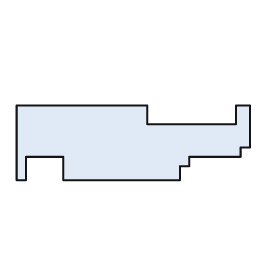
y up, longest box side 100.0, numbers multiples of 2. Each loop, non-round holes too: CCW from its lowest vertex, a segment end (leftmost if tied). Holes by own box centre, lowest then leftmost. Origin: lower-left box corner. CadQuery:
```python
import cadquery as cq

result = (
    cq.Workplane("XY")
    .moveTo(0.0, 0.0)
    .lineTo(4.0, 0.0)
    .lineTo(4.0, 10.0)
    .lineTo(20.0, 10.0)
    .lineTo(20.0, 0.0)
    .lineTo(70.0, 0.0)
    .lineTo(70.0, 6.0)
    .lineTo(74.0, 6.0)
    .lineTo(74.0, 10.0)
    .lineTo(96.0, 10.0)
    .lineTo(96.0, 14.0)
    .lineTo(100.0, 14.0)
    .lineTo(100.0, 32.0)
    .lineTo(94.0, 32.0)
    .lineTo(94.0, 24.0)
    .lineTo(56.0, 24.0)
    .lineTo(56.0, 32.0)
    .lineTo(0.0, 32.0)
    .close()
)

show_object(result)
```